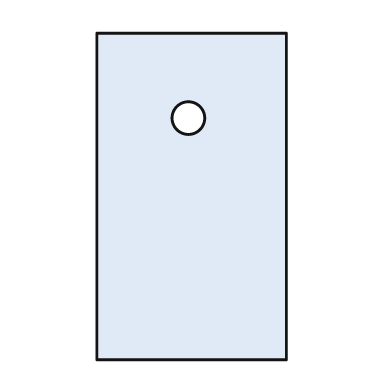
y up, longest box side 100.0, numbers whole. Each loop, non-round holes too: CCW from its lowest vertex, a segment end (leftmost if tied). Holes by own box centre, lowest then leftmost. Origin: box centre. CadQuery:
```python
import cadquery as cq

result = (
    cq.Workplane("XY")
    .moveTo(-29.0, -50.0)
    .lineTo(29.0, -50.0)
    .lineTo(29.0, 50.0)
    .lineTo(-29.0, 50.0)
    .close()
    .moveTo(-1.0, 24.0)
    .circle(5.0)
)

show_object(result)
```